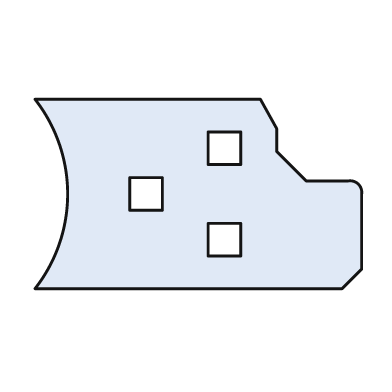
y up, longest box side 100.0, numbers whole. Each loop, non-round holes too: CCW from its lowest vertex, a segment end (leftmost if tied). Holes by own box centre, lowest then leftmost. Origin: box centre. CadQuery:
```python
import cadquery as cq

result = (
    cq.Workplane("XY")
    .moveTo(-50.0, -29.0)
    .lineTo(44.0, -29.0)
    .lineTo(50.0, -23.0)
    .lineTo(50.0, 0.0)
    .threePointArc((49.0, 3.0), (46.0, 4.0))
    .lineTo(33.0, 4.0)
    .lineTo(24.0, 13.0)
    .lineTo(24.0, 20.0)
    .lineTo(19.0, 29.0)
    .lineTo(-50.0, 29.0)
    .threePointArc((-40.0, 0.0), (-50.0, -29.0))
    .close()
    .moveTo(3.0, -19.0)
    .lineTo(13.0, -19.0)
    .lineTo(13.0, -9.0)
    .lineTo(3.0, -9.0)
    .close()
    .moveTo(-21.0, -5.0)
    .lineTo(-11.0, -5.0)
    .lineTo(-11.0, 5.0)
    .lineTo(-21.0, 5.0)
    .close()
    .moveTo(3.0, 9.0)
    .lineTo(13.0, 9.0)
    .lineTo(13.0, 19.0)
    .lineTo(3.0, 19.0)
    .close()
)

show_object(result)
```